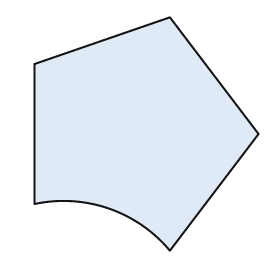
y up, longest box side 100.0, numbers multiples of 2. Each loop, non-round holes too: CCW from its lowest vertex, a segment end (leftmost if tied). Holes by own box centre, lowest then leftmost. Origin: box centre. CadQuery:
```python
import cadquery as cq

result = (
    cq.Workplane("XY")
    .moveTo(10.0, -50.0)
    .lineTo(48.0, 0.0)
    .lineTo(10.0, 50.0)
    .lineTo(-48.0, 30.0)
    .lineTo(-48.0, -30.0)
    .threePointArc((-16.0, -32.0), (10.0, -50.0))
    .close()
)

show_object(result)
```